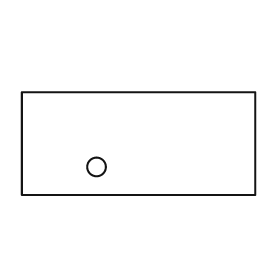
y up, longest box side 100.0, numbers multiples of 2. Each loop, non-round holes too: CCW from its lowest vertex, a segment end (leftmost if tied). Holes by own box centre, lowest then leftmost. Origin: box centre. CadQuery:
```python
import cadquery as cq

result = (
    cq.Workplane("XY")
    .moveTo(-50.0, -22.0)
    .lineTo(50.0, -22.0)
    .lineTo(50.0, 22.0)
    .lineTo(-50.0, 22.0)
    .close()
    .moveTo(-18.0, -10.0)
    .circle(4.0)
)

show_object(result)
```